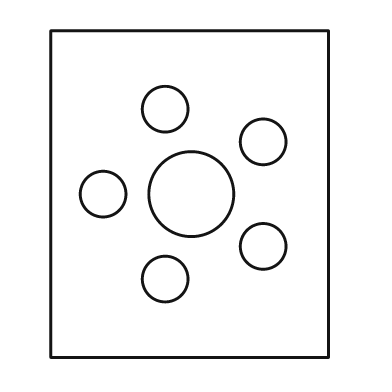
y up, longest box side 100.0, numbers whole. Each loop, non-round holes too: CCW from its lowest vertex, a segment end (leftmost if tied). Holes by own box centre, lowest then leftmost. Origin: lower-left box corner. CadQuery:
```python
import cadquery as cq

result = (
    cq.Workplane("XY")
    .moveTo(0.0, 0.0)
    .lineTo(85.0, 0.0)
    .lineTo(85.0, 100.0)
    .lineTo(0.0, 100.0)
    .close()
    .moveTo(35.0, 24.0)
    .circle(7.0)
    .moveTo(65.0, 34.0)
    .circle(7.0)
    .moveTo(16.0, 50.0)
    .circle(7.0)
    .moveTo(43.0, 50.0)
    .circle(13.0)
    .moveTo(65.0, 66.0)
    .circle(7.0)
    .moveTo(35.0, 76.0)
    .circle(7.0)
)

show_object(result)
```